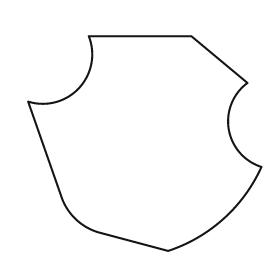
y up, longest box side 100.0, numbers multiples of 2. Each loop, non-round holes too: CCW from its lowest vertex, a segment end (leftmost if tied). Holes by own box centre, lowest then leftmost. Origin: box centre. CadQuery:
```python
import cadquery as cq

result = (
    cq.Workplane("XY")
    .moveTo(10.0, -46.0)
    .threePointArc((34.0, -32.0), (50.0, -10.0))
    .threePointArc((36.0, 6.0), (44.0, 26.0))
    .lineTo(20.0, 46.0)
    .lineTo(-24.0, 46.0)
    .threePointArc((-28.0, 24.0), (-50.0, 18.0))
    .lineTo(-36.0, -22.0)
    .threePointArc((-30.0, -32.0), (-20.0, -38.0))
    .close()
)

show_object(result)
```